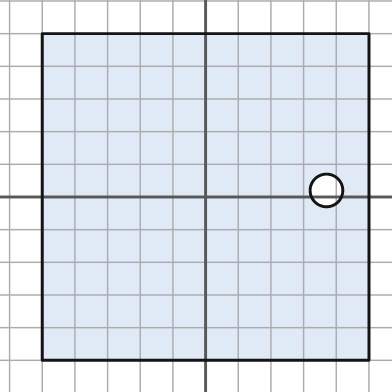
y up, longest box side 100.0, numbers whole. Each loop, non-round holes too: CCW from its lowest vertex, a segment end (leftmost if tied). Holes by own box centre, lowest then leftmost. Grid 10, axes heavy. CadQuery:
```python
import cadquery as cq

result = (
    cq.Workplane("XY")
    .moveTo(-50.0, -50.0)
    .lineTo(50.0, -50.0)
    .lineTo(50.0, 50.0)
    .lineTo(-50.0, 50.0)
    .close()
    .moveTo(37.0, 2.0)
    .circle(5.0)
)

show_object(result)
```